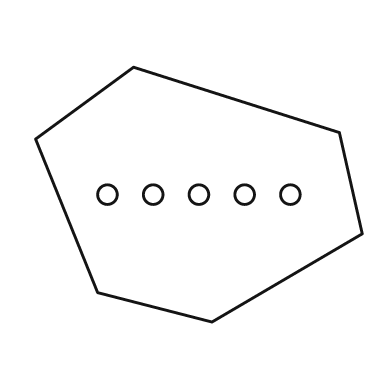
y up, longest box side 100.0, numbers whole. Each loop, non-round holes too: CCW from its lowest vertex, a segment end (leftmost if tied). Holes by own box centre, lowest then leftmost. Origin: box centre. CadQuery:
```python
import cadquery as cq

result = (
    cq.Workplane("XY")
    .moveTo(4.0, -39.0)
    .lineTo(50.0, -12.0)
    .lineTo(43.0, 19.0)
    .lineTo(-20.0, 39.0)
    .lineTo(-50.0, 17.0)
    .lineTo(-31.0, -30.0)
    .close()
    .moveTo(-28.0, 0.0)
    .circle(3.0)
    .moveTo(-14.0, 0.0)
    .circle(3.0)
    .moveTo(0.0, 0.0)
    .circle(3.0)
    .moveTo(14.0, 0.0)
    .circle(3.0)
    .moveTo(28.0, 0.0)
    .circle(3.0)
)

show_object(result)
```